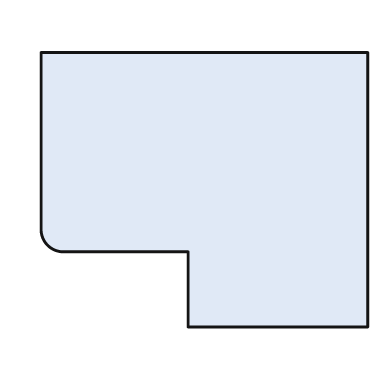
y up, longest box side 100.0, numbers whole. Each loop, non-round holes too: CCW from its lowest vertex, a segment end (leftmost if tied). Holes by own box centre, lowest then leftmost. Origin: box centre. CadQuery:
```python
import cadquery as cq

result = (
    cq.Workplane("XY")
    .moveTo(-5.0, -42.0)
    .lineTo(50.0, -42.0)
    .lineTo(50.0, 42.0)
    .lineTo(-50.0, 42.0)
    .lineTo(-50.0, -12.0)
    .threePointArc((-48.0, -17.0), (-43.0, -19.0))
    .lineTo(-5.0, -19.0)
    .close()
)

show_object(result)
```